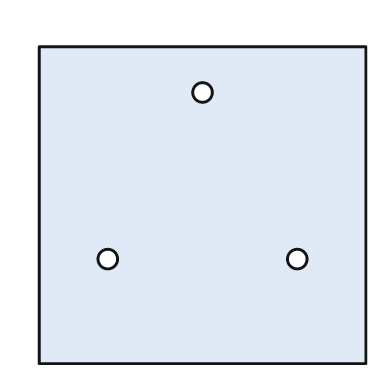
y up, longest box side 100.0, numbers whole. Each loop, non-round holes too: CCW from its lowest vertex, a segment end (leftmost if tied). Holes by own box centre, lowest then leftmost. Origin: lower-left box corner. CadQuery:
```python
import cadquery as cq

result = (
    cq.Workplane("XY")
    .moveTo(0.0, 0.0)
    .lineTo(100.0, 0.0)
    .lineTo(100.0, 97.0)
    .lineTo(0.0, 97.0)
    .close()
    .moveTo(21.0, 32.0)
    .circle(3.0)
    .moveTo(79.0, 32.0)
    .circle(3.0)
    .moveTo(50.0, 83.0)
    .circle(3.0)
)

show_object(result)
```